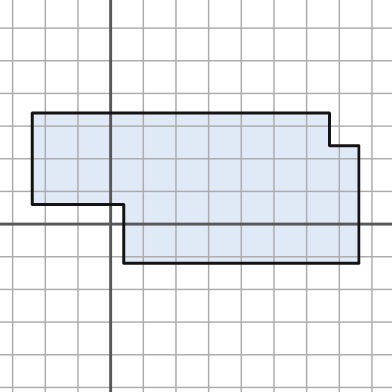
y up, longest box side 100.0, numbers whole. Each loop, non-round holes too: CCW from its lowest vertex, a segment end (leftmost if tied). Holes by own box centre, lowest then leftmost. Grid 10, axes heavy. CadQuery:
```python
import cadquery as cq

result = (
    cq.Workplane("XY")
    .moveTo(4.0, -12.0)
    .lineTo(76.0, -12.0)
    .lineTo(76.0, 24.0)
    .lineTo(67.0, 24.0)
    .lineTo(67.0, 34.0)
    .lineTo(-24.0, 34.0)
    .lineTo(-24.0, 6.0)
    .lineTo(4.0, 6.0)
    .close()
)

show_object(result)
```